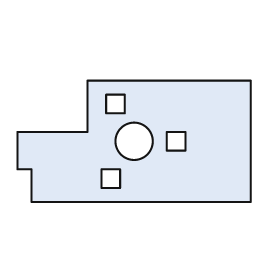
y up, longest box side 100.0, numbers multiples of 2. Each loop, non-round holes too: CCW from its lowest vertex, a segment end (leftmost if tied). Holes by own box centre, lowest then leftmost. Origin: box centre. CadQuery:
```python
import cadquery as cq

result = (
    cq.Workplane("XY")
    .moveTo(-44.0, -26.0)
    .lineTo(50.0, -26.0)
    .lineTo(50.0, 26.0)
    .lineTo(-20.0, 26.0)
    .lineTo(-20.0, 4.0)
    .lineTo(-50.0, 4.0)
    .lineTo(-50.0, -12.0)
    .lineTo(-44.0, -12.0)
    .close()
    .moveTo(-14.0, -20.0)
    .lineTo(-6.0, -20.0)
    .lineTo(-6.0, -12.0)
    .lineTo(-14.0, -12.0)
    .close()
    .moveTo(0.0, 0.0)
    .circle(8.0)
    .moveTo(14.0, -4.0)
    .lineTo(22.0, -4.0)
    .lineTo(22.0, 4.0)
    .lineTo(14.0, 4.0)
    .close()
    .moveTo(-12.0, 12.0)
    .lineTo(-4.0, 12.0)
    .lineTo(-4.0, 20.0)
    .lineTo(-12.0, 20.0)
    .close()
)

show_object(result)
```